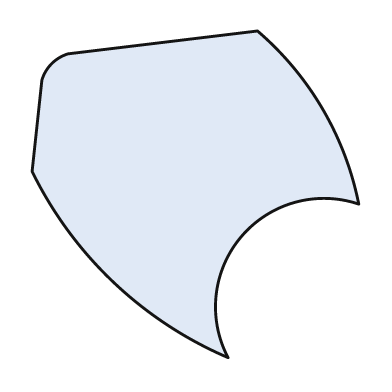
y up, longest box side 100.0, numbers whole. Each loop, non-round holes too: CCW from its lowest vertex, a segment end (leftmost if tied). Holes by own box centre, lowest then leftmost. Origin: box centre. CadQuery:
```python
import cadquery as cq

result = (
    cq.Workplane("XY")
    .moveTo(10.0, -50.0)
    .threePointArc((14.0, -13.0), (50.0, -3.0))
    .threePointArc((39.0, 26.0), (19.0, 50.0))
    .lineTo(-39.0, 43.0)
    .threePointArc((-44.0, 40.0), (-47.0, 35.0))
    .lineTo(-50.0, 7.0)
    .threePointArc((-25.0, -27.0), (10.0, -50.0))
    .close()
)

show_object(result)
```